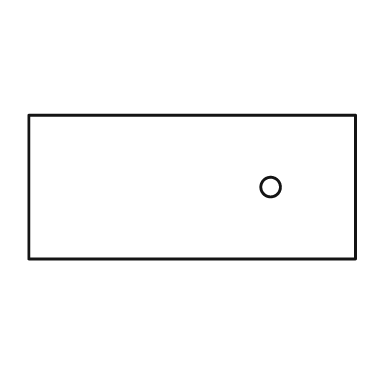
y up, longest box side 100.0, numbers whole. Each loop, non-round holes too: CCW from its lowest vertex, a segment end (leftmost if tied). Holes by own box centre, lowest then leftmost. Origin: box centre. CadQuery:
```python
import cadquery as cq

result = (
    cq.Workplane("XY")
    .moveTo(-50.0, -22.0)
    .lineTo(50.0, -22.0)
    .lineTo(50.0, 22.0)
    .lineTo(-50.0, 22.0)
    .close()
    .moveTo(24.0, 0.0)
    .circle(3.0)
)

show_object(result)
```